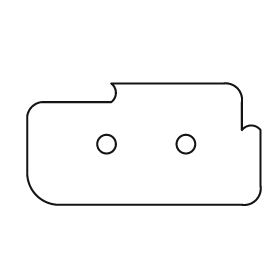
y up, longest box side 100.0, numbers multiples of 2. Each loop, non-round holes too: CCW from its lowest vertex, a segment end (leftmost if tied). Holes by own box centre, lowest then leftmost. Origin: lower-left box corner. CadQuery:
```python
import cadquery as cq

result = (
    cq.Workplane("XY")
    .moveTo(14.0, 0.0)
    .lineTo(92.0, 0.0)
    .threePointArc((98.0, 2.0), (100.0, 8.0))
    .lineTo(100.0, 32.0)
    .threePointArc((96.0, 34.0), (92.0, 32.0))
    .lineTo(92.0, 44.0)
    .threePointArc((90.0, 50.0), (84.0, 52.0))
    .lineTo(36.0, 52.0)
    .threePointArc((38.0, 48.0), (36.0, 44.0))
    .lineTo(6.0, 44.0)
    .threePointArc((2.0, 42.0), (0.0, 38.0))
    .lineTo(0.0, 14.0)
    .threePointArc((4.0, 4.0), (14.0, 0.0))
    .close()
    .moveTo(34.0, 26.0)
    .circle(4.0)
    .moveTo(68.0, 26.0)
    .circle(4.0)
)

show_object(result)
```